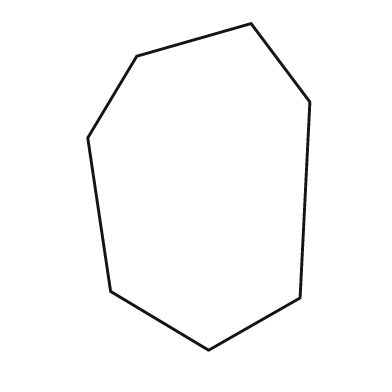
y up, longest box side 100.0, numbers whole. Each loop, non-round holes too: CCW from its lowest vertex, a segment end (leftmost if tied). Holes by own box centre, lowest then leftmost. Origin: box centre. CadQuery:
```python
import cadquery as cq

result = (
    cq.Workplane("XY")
    .moveTo(3.0, -50.0)
    .lineTo(31.0, -34.0)
    .lineTo(34.0, 26.0)
    .lineTo(16.0, 50.0)
    .lineTo(-19.0, 40.0)
    .lineTo(-34.0, 15.0)
    .lineTo(-27.0, -32.0)
    .close()
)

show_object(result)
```